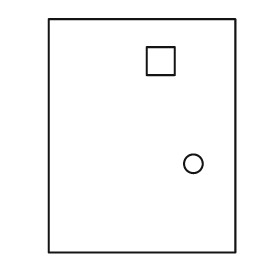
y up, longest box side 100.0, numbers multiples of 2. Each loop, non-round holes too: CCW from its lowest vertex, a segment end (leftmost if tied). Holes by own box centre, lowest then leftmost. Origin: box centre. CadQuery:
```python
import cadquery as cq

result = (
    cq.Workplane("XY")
    .moveTo(-40.0, -50.0)
    .lineTo(40.0, -50.0)
    .lineTo(40.0, 50.0)
    .lineTo(-40.0, 50.0)
    .close()
    .moveTo(22.0, -12.0)
    .circle(4.0)
    .moveTo(2.0, 26.0)
    .lineTo(14.0, 26.0)
    .lineTo(14.0, 38.0)
    .lineTo(2.0, 38.0)
    .close()
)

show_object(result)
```